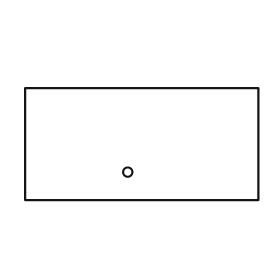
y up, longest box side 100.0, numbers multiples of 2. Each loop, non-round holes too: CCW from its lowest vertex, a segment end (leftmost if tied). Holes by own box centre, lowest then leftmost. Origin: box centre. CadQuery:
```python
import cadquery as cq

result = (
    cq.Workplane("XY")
    .moveTo(-50.0, -24.0)
    .lineTo(50.0, -24.0)
    .lineTo(50.0, 24.0)
    .lineTo(-50.0, 24.0)
    .close()
    .moveTo(-6.0, -12.0)
    .circle(2.0)
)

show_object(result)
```